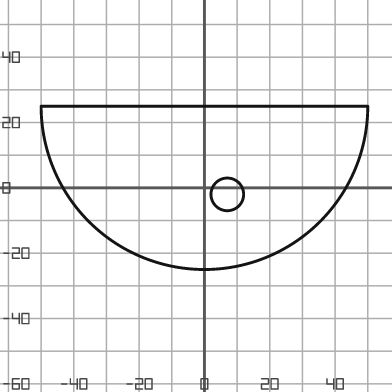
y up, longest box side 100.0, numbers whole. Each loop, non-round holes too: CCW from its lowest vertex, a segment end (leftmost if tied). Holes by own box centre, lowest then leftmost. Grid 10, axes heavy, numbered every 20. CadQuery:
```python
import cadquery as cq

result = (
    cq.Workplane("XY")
    .moveTo(-50.0, 25.0)
    .threePointArc((0.0, -25.0), (50.0, 25.0))
    .close()
    .moveTo(7.0, -2.0)
    .circle(5.0)
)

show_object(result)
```